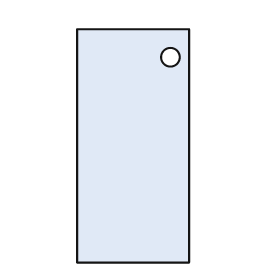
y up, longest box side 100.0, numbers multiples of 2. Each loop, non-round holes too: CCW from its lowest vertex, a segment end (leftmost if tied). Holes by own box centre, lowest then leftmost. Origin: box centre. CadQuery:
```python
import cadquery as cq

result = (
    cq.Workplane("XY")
    .moveTo(-24.0, -50.0)
    .lineTo(24.0, -50.0)
    .lineTo(24.0, 50.0)
    .lineTo(-24.0, 50.0)
    .close()
    .moveTo(16.0, 38.0)
    .circle(4.0)
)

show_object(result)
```